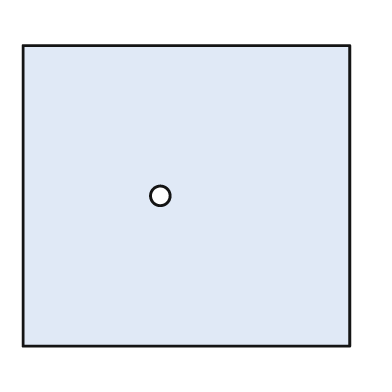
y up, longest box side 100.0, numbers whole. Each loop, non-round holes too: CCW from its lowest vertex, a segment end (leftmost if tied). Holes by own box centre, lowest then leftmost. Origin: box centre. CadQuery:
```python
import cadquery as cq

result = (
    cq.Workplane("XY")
    .moveTo(-50.0, -46.0)
    .lineTo(50.0, -46.0)
    .lineTo(50.0, 46.0)
    .lineTo(-50.0, 46.0)
    .close()
    .moveTo(-8.0, 0.0)
    .circle(3.0)
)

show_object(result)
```